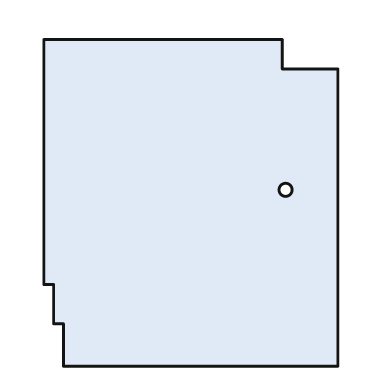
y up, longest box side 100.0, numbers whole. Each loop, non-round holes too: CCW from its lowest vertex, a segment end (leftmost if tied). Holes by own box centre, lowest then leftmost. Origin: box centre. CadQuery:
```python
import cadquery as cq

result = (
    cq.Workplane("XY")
    .moveTo(-39.0, -50.0)
    .lineTo(45.0, -50.0)
    .lineTo(45.0, 41.0)
    .lineTo(28.0, 41.0)
    .lineTo(28.0, 50.0)
    .lineTo(-45.0, 50.0)
    .lineTo(-45.0, -25.0)
    .lineTo(-42.0, -25.0)
    .lineTo(-42.0, -37.0)
    .lineTo(-39.0, -37.0)
    .close()
    .moveTo(29.0, 4.0)
    .circle(2.0)
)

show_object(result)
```